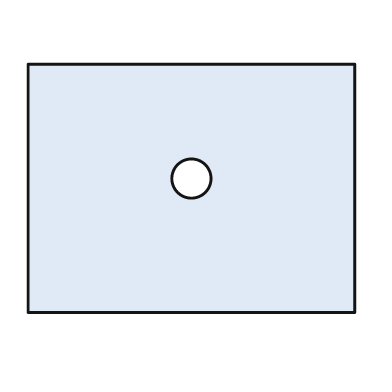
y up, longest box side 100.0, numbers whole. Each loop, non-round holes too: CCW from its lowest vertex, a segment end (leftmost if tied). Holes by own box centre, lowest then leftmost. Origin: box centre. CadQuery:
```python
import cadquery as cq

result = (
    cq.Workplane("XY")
    .moveTo(-50.0, -38.0)
    .lineTo(50.0, -38.0)
    .lineTo(50.0, 38.0)
    .lineTo(-50.0, 38.0)
    .close()
    .moveTo(0.0, 3.0)
    .circle(6.0)
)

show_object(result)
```